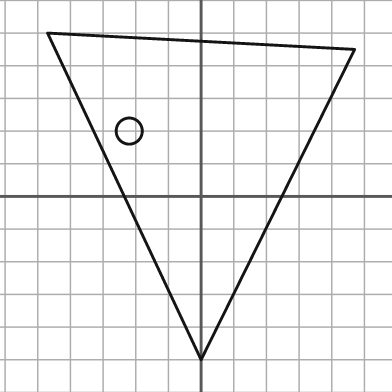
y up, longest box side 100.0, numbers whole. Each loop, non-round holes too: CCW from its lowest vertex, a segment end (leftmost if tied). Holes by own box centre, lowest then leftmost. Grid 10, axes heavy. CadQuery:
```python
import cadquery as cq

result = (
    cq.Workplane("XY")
    .moveTo(0.0, -50.0)
    .lineTo(47.0, 45.0)
    .lineTo(-47.0, 50.0)
    .close()
    .moveTo(-22.0, 20.0)
    .circle(4.0)
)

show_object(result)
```